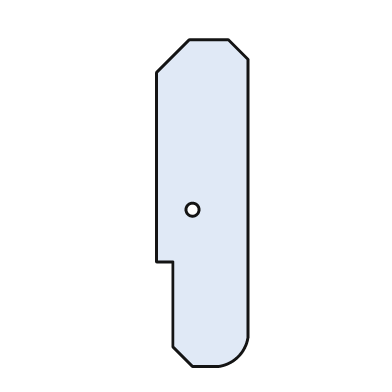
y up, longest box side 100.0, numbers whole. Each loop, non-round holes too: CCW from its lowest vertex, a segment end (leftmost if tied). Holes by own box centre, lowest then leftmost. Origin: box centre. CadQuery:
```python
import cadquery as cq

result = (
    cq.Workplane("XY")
    .moveTo(-3.0, -50.0)
    .lineTo(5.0, -50.0)
    .threePointArc((11.0, -47.0), (14.0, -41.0))
    .lineTo(14.0, 44.0)
    .lineTo(8.0, 50.0)
    .lineTo(-4.0, 50.0)
    .lineTo(-14.0, 40.0)
    .lineTo(-14.0, -18.0)
    .lineTo(-9.0, -18.0)
    .lineTo(-9.0, -44.0)
    .close()
    .moveTo(-3.0, -2.0)
    .circle(2.0)
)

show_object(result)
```